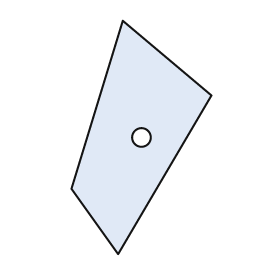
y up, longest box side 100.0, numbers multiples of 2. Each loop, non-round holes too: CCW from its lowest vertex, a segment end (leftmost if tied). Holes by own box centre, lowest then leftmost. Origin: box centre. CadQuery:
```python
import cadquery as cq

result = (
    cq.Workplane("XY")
    .moveTo(-10.0, -50.0)
    .lineTo(30.0, 18.0)
    .lineTo(-8.0, 50.0)
    .lineTo(-30.0, -22.0)
    .close()
    .moveTo(0.0, 0.0)
    .circle(4.0)
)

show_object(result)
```